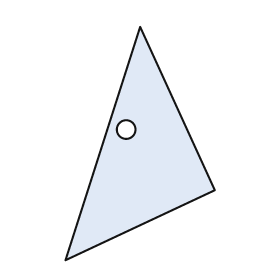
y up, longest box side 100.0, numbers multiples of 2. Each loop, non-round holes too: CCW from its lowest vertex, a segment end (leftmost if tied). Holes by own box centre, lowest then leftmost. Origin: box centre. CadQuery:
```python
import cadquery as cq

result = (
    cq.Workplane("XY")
    .moveTo(-32.0, -50.0)
    .lineTo(32.0, -20.0)
    .lineTo(0.0, 50.0)
    .close()
    .moveTo(-6.0, 6.0)
    .circle(4.0)
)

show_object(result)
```